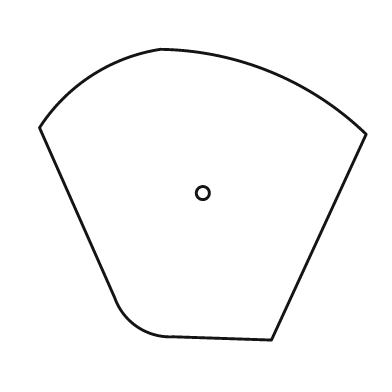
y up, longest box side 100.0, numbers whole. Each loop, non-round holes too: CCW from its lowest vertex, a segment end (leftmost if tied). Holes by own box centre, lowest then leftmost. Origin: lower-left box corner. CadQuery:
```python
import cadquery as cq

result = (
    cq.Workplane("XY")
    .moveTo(71.0, 0.0)
    .lineTo(100.0, 63.0)
    .threePointArc((71.0, 82.0), (37.0, 89.0))
    .threePointArc((16.0, 81.0), (0.0, 65.0))
    .lineTo(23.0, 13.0)
    .threePointArc((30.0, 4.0), (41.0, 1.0))
    .close()
    .moveTo(50.0, 45.0)
    .circle(2.0)
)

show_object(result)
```